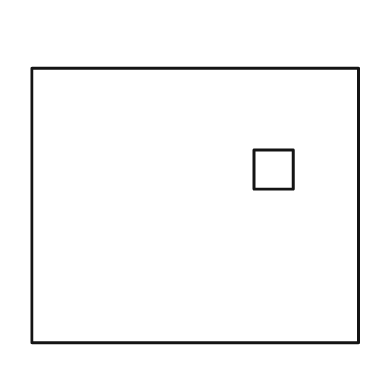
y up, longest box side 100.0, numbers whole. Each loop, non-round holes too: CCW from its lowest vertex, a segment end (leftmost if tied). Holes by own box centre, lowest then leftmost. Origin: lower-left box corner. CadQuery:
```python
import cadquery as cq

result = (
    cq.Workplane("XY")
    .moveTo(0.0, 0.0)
    .lineTo(100.0, 0.0)
    .lineTo(100.0, 84.0)
    .lineTo(0.0, 84.0)
    .close()
    .moveTo(68.0, 47.0)
    .lineTo(80.0, 47.0)
    .lineTo(80.0, 59.0)
    .lineTo(68.0, 59.0)
    .close()
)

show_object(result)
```